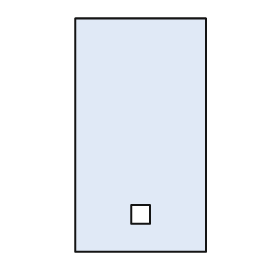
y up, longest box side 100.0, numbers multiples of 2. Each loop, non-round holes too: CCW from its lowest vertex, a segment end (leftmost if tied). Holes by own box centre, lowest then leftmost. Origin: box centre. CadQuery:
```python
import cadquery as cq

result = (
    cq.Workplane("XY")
    .moveTo(-28.0, -50.0)
    .lineTo(28.0, -50.0)
    .lineTo(28.0, 50.0)
    .lineTo(-28.0, 50.0)
    .close()
    .moveTo(-4.0, -38.0)
    .lineTo(4.0, -38.0)
    .lineTo(4.0, -30.0)
    .lineTo(-4.0, -30.0)
    .close()
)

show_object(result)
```